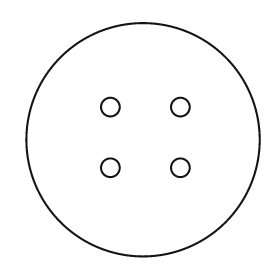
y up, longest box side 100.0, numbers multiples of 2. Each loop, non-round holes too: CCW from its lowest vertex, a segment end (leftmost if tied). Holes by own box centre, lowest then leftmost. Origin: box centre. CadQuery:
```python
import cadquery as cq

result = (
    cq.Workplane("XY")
    .moveTo(0.0, 0.0)
    .circle(50.0)
    .moveTo(-14.0, -12.0)
    .circle(4.0)
    .moveTo(16.0, -12.0)
    .circle(4.0)
    .moveTo(-14.0, 14.0)
    .circle(4.0)
    .moveTo(16.0, 14.0)
    .circle(4.0)
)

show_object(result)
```